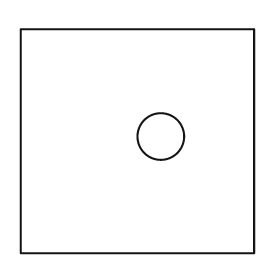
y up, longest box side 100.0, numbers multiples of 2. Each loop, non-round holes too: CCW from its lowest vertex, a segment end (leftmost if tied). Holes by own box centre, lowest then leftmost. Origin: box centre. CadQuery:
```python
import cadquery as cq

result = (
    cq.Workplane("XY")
    .moveTo(-50.0, -48.0)
    .lineTo(50.0, -48.0)
    .lineTo(50.0, 48.0)
    .lineTo(-50.0, 48.0)
    .close()
    .moveTo(10.0, 2.0)
    .circle(10.0)
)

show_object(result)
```